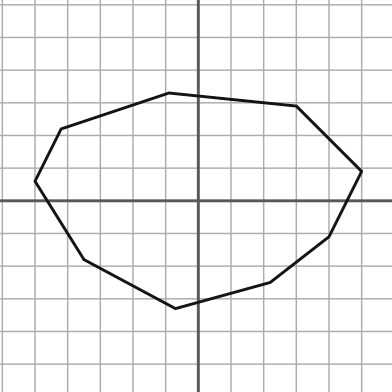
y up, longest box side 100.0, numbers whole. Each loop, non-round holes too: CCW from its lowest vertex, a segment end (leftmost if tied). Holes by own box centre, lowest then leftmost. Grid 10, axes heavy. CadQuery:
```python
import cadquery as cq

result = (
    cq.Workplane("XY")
    .moveTo(-7.0, -33.0)
    .lineTo(22.0, -25.0)
    .lineTo(40.0, -11.0)
    .lineTo(50.0, 9.0)
    .lineTo(30.0, 29.0)
    .lineTo(-9.0, 33.0)
    .lineTo(-42.0, 22.0)
    .lineTo(-50.0, 6.0)
    .lineTo(-35.0, -18.0)
    .close()
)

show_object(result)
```